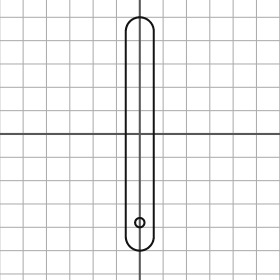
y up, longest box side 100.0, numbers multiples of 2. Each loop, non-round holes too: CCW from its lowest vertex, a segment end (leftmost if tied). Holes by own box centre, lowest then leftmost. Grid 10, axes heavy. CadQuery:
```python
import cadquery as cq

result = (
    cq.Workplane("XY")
    .moveTo(-6.0, -44.0)
    .threePointArc((0.0, -50.0), (6.0, -44.0))
    .lineTo(6.0, 44.0)
    .threePointArc((0.0, 50.0), (-6.0, 44.0))
    .close()
    .moveTo(0.0, -38.0)
    .circle(2.0)
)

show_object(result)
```